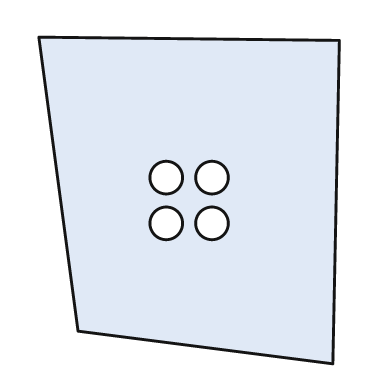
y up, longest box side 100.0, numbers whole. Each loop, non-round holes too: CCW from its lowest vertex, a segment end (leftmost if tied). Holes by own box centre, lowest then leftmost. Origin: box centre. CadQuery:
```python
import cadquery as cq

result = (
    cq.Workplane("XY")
    .moveTo(44.0, -50.0)
    .lineTo(46.0, 49.0)
    .lineTo(-46.0, 50.0)
    .lineTo(-34.0, -40.0)
    .close()
    .moveTo(-7.0, -7.0)
    .circle(5.0)
    .moveTo(7.0, -7.0)
    .circle(5.0)
    .moveTo(-7.0, 7.0)
    .circle(5.0)
    .moveTo(7.0, 7.0)
    .circle(5.0)
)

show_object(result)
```